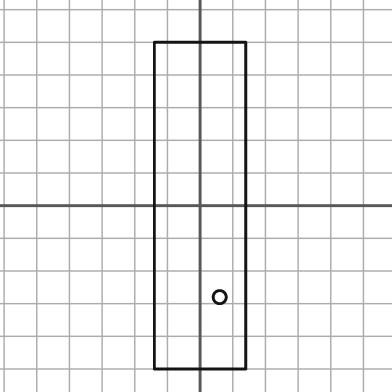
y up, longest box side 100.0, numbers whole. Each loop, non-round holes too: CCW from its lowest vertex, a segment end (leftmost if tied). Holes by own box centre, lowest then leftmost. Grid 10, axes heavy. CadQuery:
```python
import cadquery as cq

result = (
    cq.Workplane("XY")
    .moveTo(-14.0, -50.0)
    .lineTo(14.0, -50.0)
    .lineTo(14.0, 50.0)
    .lineTo(-14.0, 50.0)
    .close()
    .moveTo(6.0, -28.0)
    .circle(2.0)
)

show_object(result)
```